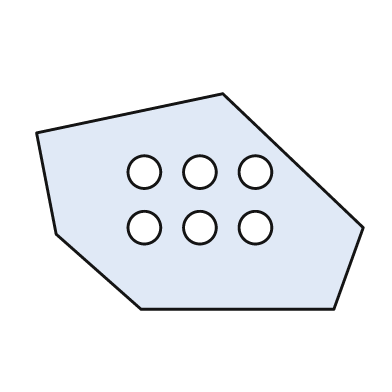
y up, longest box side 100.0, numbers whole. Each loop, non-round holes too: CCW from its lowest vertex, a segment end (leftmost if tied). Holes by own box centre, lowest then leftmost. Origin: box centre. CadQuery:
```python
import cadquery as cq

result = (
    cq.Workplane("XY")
    .moveTo(-18.0, -33.0)
    .lineTo(41.0, -33.0)
    .lineTo(50.0, -8.0)
    .lineTo(7.0, 33.0)
    .lineTo(-50.0, 21.0)
    .lineTo(-44.0, -10.0)
    .close()
    .moveTo(-17.0, -8.0)
    .circle(5.0)
    .moveTo(0.0, -8.0)
    .circle(5.0)
    .moveTo(17.0, -8.0)
    .circle(5.0)
    .moveTo(-17.0, 9.0)
    .circle(5.0)
    .moveTo(0.0, 9.0)
    .circle(5.0)
    .moveTo(17.0, 9.0)
    .circle(5.0)
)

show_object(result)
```